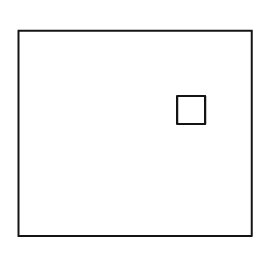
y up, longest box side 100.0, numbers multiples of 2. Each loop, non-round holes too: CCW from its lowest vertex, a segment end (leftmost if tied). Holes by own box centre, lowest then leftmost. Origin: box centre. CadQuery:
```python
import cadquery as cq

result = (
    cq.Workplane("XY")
    .moveTo(-50.0, -44.0)
    .lineTo(50.0, -44.0)
    .lineTo(50.0, 44.0)
    .lineTo(-50.0, 44.0)
    .close()
    .moveTo(18.0, 4.0)
    .lineTo(30.0, 4.0)
    .lineTo(30.0, 16.0)
    .lineTo(18.0, 16.0)
    .close()
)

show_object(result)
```